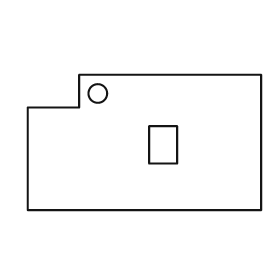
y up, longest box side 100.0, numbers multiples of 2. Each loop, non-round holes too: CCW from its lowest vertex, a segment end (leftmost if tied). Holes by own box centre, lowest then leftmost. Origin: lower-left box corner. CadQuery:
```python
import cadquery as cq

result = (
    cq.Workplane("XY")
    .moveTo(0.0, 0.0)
    .lineTo(100.0, 0.0)
    .lineTo(100.0, 58.0)
    .lineTo(22.0, 58.0)
    .lineTo(22.0, 44.0)
    .lineTo(0.0, 44.0)
    .close()
    .moveTo(52.0, 20.0)
    .lineTo(64.0, 20.0)
    .lineTo(64.0, 36.0)
    .lineTo(52.0, 36.0)
    .close()
    .moveTo(30.0, 50.0)
    .circle(4.0)
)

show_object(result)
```